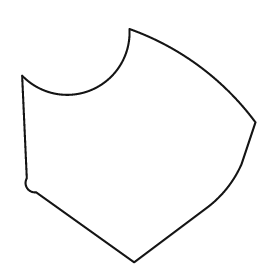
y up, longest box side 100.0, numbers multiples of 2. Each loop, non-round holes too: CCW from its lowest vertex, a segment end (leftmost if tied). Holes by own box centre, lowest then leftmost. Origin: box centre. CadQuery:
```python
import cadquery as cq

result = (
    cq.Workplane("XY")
    .moveTo(-2.0, -50.0)
    .lineTo(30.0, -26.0)
    .threePointArc((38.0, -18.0), (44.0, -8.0))
    .lineTo(50.0, 10.0)
    .threePointArc((26.0, 34.0), (-4.0, 50.0))
    .threePointArc((-20.0, 24.0), (-50.0, 30.0))
    .lineTo(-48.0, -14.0)
    .threePointArc((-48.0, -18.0), (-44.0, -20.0))
    .close()
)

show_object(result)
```